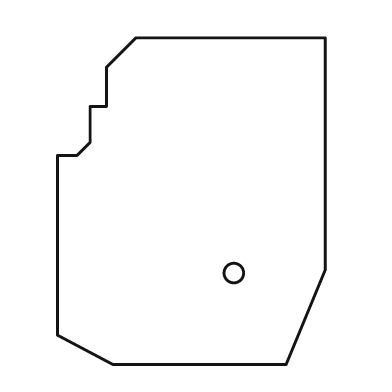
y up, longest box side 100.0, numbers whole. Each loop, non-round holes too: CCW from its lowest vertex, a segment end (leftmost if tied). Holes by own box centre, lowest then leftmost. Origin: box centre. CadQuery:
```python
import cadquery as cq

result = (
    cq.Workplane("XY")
    .moveTo(-24.0, -50.0)
    .lineTo(29.0, -50.0)
    .lineTo(41.0, -21.0)
    .lineTo(41.0, 50.0)
    .lineTo(-17.0, 50.0)
    .lineTo(-26.0, 41.0)
    .lineTo(-26.0, 29.0)
    .lineTo(-31.0, 29.0)
    .lineTo(-31.0, 18.0)
    .lineTo(-35.0, 14.0)
    .lineTo(-41.0, 14.0)
    .lineTo(-41.0, -41.0)
    .close()
    .moveTo(13.0, -22.0)
    .circle(3.0)
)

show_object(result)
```